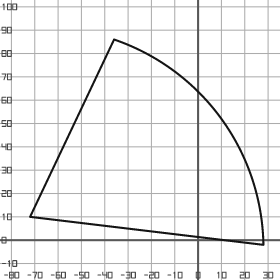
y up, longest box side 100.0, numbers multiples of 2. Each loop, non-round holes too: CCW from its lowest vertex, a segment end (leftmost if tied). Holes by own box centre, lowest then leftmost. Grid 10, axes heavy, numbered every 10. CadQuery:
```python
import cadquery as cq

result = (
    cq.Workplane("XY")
    .moveTo(28.0, -2.0)
    .threePointArc((10.0, 52.0), (-36.0, 86.0))
    .lineTo(-72.0, 10.0)
    .close()
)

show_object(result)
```